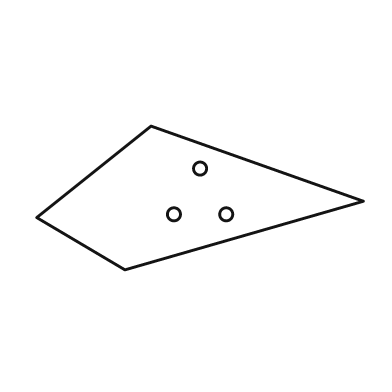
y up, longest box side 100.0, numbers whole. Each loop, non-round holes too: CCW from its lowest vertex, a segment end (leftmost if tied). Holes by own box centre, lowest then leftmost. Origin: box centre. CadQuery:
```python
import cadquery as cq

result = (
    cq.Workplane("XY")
    .moveTo(-23.0, -22.0)
    .lineTo(50.0, -1.0)
    .lineTo(-15.0, 22.0)
    .lineTo(-50.0, -6.0)
    .close()
    .moveTo(-8.0, -5.0)
    .circle(2.0)
    .moveTo(8.0, -5.0)
    .circle(2.0)
    .moveTo(0.0, 9.0)
    .circle(2.0)
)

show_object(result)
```